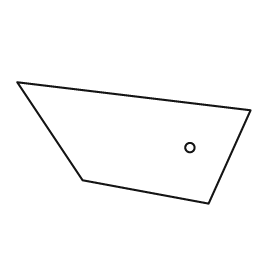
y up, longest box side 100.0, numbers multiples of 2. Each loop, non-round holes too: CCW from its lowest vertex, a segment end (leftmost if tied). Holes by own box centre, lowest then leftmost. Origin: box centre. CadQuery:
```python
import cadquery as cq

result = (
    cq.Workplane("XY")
    .moveTo(32.0, -26.0)
    .lineTo(50.0, 14.0)
    .lineTo(-50.0, 26.0)
    .lineTo(-22.0, -16.0)
    .close()
    .moveTo(24.0, -2.0)
    .circle(2.0)
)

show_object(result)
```